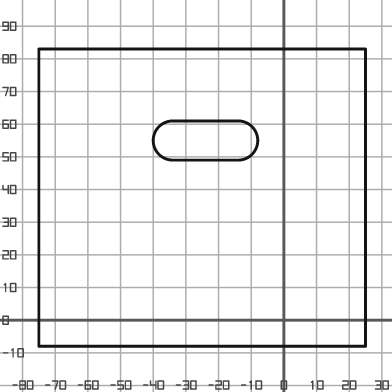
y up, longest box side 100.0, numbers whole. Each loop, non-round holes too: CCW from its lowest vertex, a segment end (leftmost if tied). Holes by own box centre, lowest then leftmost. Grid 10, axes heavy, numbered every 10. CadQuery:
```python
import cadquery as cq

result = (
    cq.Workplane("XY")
    .moveTo(-75.0, -8.0)
    .lineTo(25.0, -8.0)
    .lineTo(25.0, 83.0)
    .lineTo(-75.0, 83.0)
    .close()
    .moveTo(-34.0, 49.0)
    .lineTo(-14.0, 49.0)
    .threePointArc((-8.0, 55.0), (-14.0, 61.0))
    .lineTo(-34.0, 61.0)
    .threePointArc((-40.0, 55.0), (-34.0, 49.0))
    .close()
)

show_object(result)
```